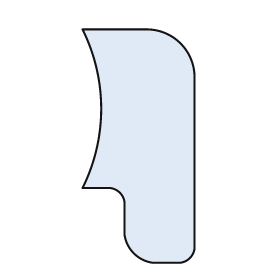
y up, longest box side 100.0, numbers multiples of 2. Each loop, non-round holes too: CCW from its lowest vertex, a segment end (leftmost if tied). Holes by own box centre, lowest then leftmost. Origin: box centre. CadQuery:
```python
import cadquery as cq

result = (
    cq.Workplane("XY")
    .moveTo(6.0, -50.0)
    .lineTo(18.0, -50.0)
    .threePointArc((22.0, -48.0), (24.0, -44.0))
    .lineTo(24.0, 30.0)
    .threePointArc((18.0, 44.0), (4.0, 50.0))
    .lineTo(-24.0, 50.0)
    .threePointArc((-16.0, 16.0), (-24.0, -18.0))
    .lineTo(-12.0, -18.0)
    .threePointArc((-8.0, -20.0), (-6.0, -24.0))
    .lineTo(-6.0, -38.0)
    .threePointArc((-2.0, -46.0), (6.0, -50.0))
    .close()
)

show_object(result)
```